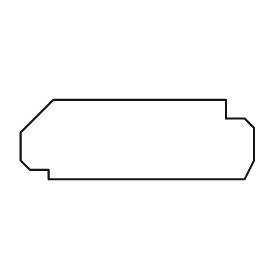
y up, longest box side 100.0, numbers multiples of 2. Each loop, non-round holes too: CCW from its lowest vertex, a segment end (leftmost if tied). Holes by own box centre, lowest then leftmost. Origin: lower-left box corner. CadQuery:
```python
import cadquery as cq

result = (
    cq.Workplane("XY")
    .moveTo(12.0, 0.0)
    .lineTo(96.0, 0.0)
    .lineTo(100.0, 8.0)
    .lineTo(100.0, 22.0)
    .lineTo(96.0, 26.0)
    .lineTo(88.0, 26.0)
    .lineTo(88.0, 34.0)
    .lineTo(14.0, 34.0)
    .lineTo(0.0, 20.0)
    .lineTo(0.0, 8.0)
    .lineTo(4.0, 4.0)
    .lineTo(12.0, 4.0)
    .close()
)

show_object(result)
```